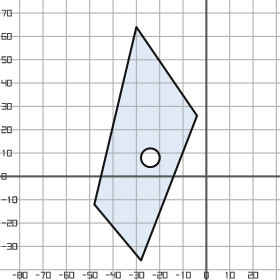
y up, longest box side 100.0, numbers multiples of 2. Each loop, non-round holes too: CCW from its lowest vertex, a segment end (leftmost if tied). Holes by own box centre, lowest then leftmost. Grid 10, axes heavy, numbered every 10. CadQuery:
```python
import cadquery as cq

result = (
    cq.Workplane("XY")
    .moveTo(-28.0, -36.0)
    .lineTo(-4.0, 26.0)
    .lineTo(-30.0, 64.0)
    .lineTo(-48.0, -12.0)
    .close()
    .moveTo(-24.0, 8.0)
    .circle(4.0)
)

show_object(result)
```